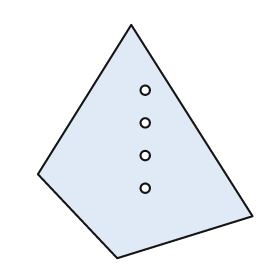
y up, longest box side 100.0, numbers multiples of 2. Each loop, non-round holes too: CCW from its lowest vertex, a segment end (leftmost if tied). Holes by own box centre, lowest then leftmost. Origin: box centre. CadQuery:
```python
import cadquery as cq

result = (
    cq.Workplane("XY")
    .moveTo(-12.0, -50.0)
    .lineTo(46.0, -32.0)
    .lineTo(-6.0, 50.0)
    .lineTo(-46.0, -14.0)
    .close()
    .moveTo(0.0, -20.0)
    .circle(2.0)
    .moveTo(0.0, -6.0)
    .circle(2.0)
    .moveTo(0.0, 8.0)
    .circle(2.0)
    .moveTo(0.0, 22.0)
    .circle(2.0)
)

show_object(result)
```